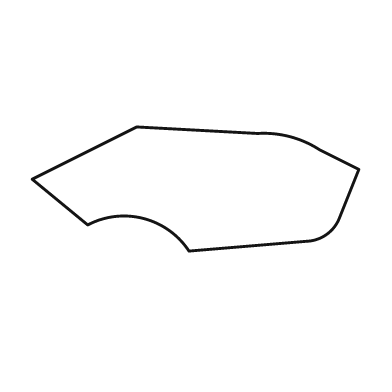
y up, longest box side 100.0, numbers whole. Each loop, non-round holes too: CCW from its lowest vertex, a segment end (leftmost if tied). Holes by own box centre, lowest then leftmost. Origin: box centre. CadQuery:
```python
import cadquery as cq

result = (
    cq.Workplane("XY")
    .moveTo(-2.0, -19.0)
    .lineTo(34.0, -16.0)
    .threePointArc((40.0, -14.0), (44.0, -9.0))
    .lineTo(50.0, 6.0)
    .lineTo(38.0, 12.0)
    .threePointArc((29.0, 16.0), (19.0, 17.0))
    .lineTo(-18.0, 19.0)
    .lineTo(-50.0, 3.0)
    .lineTo(-33.0, -11.0)
    .threePointArc((-16.0, -9.0), (-2.0, -19.0))
    .close()
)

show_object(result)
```